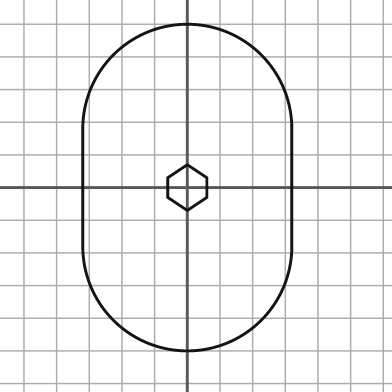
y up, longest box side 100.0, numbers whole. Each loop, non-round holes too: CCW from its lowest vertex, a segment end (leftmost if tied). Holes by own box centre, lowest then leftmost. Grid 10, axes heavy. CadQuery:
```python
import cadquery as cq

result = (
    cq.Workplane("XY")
    .moveTo(-32.0, -18.0)
    .threePointArc((0.0, -50.0), (32.0, -18.0))
    .lineTo(32.0, 18.0)
    .threePointArc((0.0, 50.0), (-32.0, 18.0))
    .close()
    .moveTo(0.0, -7.0)
    .lineTo(6.0, -3.0)
    .lineTo(6.0, 3.0)
    .lineTo(0.0, 7.0)
    .lineTo(-6.0, 3.0)
    .lineTo(-6.0, -3.0)
    .close()
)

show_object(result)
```